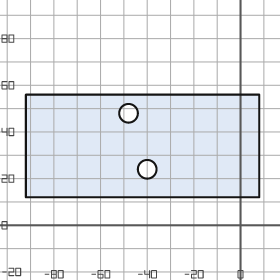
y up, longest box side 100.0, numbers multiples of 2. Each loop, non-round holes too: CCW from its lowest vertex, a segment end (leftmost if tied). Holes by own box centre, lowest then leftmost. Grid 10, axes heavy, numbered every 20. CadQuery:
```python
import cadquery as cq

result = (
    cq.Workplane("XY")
    .moveTo(-92.0, 12.0)
    .lineTo(8.0, 12.0)
    .lineTo(8.0, 56.0)
    .lineTo(-92.0, 56.0)
    .close()
    .moveTo(-40.0, 24.0)
    .circle(4.0)
    .moveTo(-48.0, 48.0)
    .circle(4.0)
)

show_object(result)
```